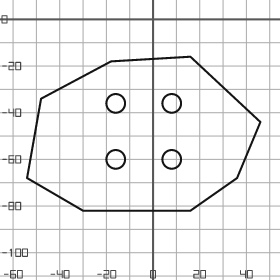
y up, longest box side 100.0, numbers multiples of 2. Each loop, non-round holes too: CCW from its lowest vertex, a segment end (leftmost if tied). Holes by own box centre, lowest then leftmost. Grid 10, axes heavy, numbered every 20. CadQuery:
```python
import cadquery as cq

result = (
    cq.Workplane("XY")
    .moveTo(-30.0, -82.0)
    .lineTo(16.0, -82.0)
    .lineTo(36.0, -68.0)
    .lineTo(46.0, -44.0)
    .lineTo(16.0, -16.0)
    .lineTo(-18.0, -18.0)
    .lineTo(-48.0, -34.0)
    .lineTo(-54.0, -68.0)
    .close()
    .moveTo(-16.0, -60.0)
    .circle(4.0)
    .moveTo(8.0, -60.0)
    .circle(4.0)
    .moveTo(-16.0, -36.0)
    .circle(4.0)
    .moveTo(8.0, -36.0)
    .circle(4.0)
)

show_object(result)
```